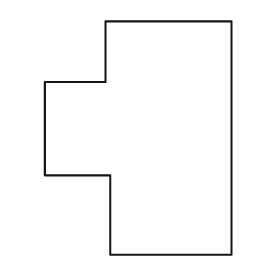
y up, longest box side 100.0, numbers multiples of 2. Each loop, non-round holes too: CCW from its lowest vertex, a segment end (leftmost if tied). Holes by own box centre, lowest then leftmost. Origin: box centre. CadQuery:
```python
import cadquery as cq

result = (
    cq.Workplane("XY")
    .moveTo(-12.0, -50.0)
    .lineTo(40.0, -50.0)
    .lineTo(40.0, 50.0)
    .lineTo(-14.0, 50.0)
    .lineTo(-14.0, 24.0)
    .lineTo(-40.0, 24.0)
    .lineTo(-40.0, -16.0)
    .lineTo(-12.0, -16.0)
    .close()
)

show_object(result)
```